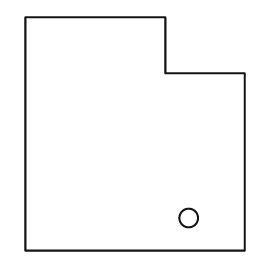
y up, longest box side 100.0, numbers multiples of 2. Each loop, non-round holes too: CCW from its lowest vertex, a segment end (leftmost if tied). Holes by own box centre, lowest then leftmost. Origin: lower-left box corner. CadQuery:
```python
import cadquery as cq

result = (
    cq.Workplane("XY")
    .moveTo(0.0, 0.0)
    .lineTo(94.0, 0.0)
    .lineTo(94.0, 76.0)
    .lineTo(60.0, 76.0)
    .lineTo(60.0, 100.0)
    .lineTo(0.0, 100.0)
    .close()
    .moveTo(70.0, 14.0)
    .circle(4.0)
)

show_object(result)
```